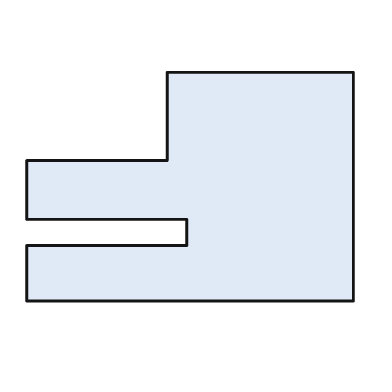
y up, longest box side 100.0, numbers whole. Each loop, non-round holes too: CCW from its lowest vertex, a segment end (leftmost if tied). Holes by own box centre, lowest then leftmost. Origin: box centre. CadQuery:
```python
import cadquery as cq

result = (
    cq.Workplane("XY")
    .moveTo(-50.0, -35.0)
    .lineTo(50.0, -35.0)
    .lineTo(50.0, 35.0)
    .lineTo(-7.0, 35.0)
    .lineTo(-7.0, 8.0)
    .lineTo(-50.0, 8.0)
    .lineTo(-50.0, -10.0)
    .lineTo(-1.0, -10.0)
    .lineTo(-1.0, -18.0)
    .lineTo(-50.0, -18.0)
    .close()
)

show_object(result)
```